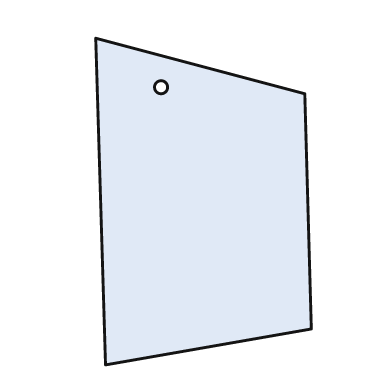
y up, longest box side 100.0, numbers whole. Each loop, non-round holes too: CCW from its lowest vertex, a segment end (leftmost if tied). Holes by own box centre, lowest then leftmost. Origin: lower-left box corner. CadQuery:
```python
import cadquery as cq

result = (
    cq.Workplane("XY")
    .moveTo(3.0, 0.0)
    .lineTo(66.0, 11.0)
    .lineTo(64.0, 83.0)
    .lineTo(0.0, 100.0)
    .close()
    .moveTo(20.0, 85.0)
    .circle(2.0)
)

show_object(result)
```